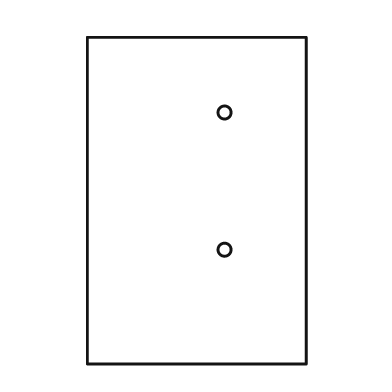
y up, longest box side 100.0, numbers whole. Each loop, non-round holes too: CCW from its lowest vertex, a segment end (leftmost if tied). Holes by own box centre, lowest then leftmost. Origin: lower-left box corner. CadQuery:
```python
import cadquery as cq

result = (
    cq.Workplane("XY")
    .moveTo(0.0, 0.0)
    .lineTo(67.0, 0.0)
    .lineTo(67.0, 100.0)
    .lineTo(0.0, 100.0)
    .close()
    .moveTo(42.0, 35.0)
    .circle(2.0)
    .moveTo(42.0, 77.0)
    .circle(2.0)
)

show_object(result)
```